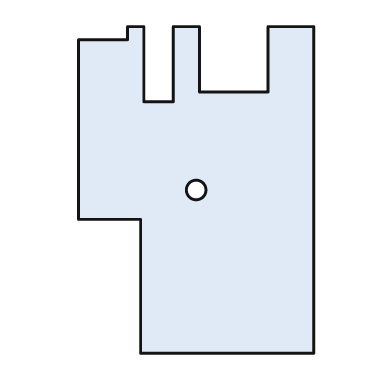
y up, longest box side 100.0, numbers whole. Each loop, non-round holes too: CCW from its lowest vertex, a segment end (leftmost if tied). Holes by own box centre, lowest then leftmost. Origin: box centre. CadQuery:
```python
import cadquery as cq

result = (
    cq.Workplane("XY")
    .moveTo(-17.0, -50.0)
    .lineTo(36.0, -50.0)
    .lineTo(36.0, 50.0)
    .lineTo(22.0, 50.0)
    .lineTo(22.0, 30.0)
    .lineTo(1.0, 30.0)
    .lineTo(1.0, 50.0)
    .lineTo(-7.0, 50.0)
    .lineTo(-7.0, 27.0)
    .lineTo(-16.0, 27.0)
    .lineTo(-16.0, 50.0)
    .lineTo(-21.0, 50.0)
    .lineTo(-21.0, 46.0)
    .lineTo(-36.0, 46.0)
    .lineTo(-36.0, -9.0)
    .lineTo(-17.0, -9.0)
    .close()
    .moveTo(0.0, 0.0)
    .circle(3.0)
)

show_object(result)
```